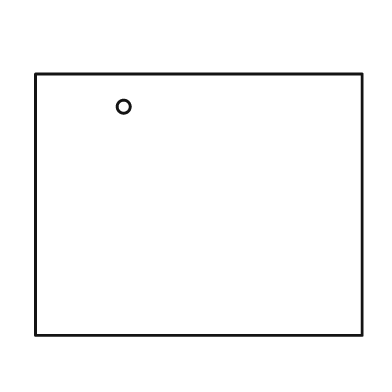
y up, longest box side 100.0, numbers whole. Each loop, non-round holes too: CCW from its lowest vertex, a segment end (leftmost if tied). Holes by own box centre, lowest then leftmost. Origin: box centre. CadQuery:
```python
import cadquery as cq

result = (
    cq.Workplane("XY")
    .moveTo(-50.0, -40.0)
    .lineTo(50.0, -40.0)
    .lineTo(50.0, 40.0)
    .lineTo(-50.0, 40.0)
    .close()
    .moveTo(-23.0, 30.0)
    .circle(2.0)
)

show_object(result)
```